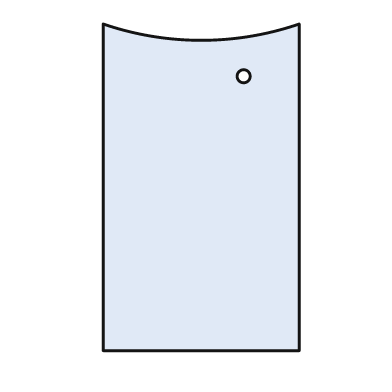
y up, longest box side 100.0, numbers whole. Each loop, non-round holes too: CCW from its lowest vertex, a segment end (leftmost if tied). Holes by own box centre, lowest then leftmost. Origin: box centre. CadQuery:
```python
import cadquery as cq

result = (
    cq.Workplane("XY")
    .moveTo(-30.0, -50.0)
    .lineTo(30.0, -50.0)
    .lineTo(30.0, 50.0)
    .threePointArc((0.0, 45.0), (-30.0, 50.0))
    .close()
    .moveTo(13.0, 34.0)
    .circle(2.0)
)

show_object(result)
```